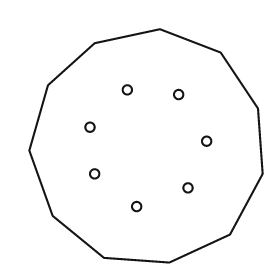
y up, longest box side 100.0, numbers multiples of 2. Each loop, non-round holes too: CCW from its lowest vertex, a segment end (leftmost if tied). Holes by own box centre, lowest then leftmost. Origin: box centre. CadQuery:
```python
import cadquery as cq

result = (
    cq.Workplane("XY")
    .moveTo(10.0, -50.0)
    .lineTo(36.0, -38.0)
    .lineTo(50.0, -12.0)
    .lineTo(48.0, 16.0)
    .lineTo(32.0, 40.0)
    .lineTo(6.0, 50.0)
    .lineTo(-22.0, 44.0)
    .lineTo(-42.0, 26.0)
    .lineTo(-50.0, -2.0)
    .lineTo(-40.0, -30.0)
    .lineTo(-18.0, -48.0)
    .close()
    .moveTo(-4.0, -26.0)
    .circle(2.0)
    .moveTo(18.0, -18.0)
    .circle(2.0)
    .moveTo(-22.0, -12.0)
    .circle(2.0)
    .moveTo(26.0, 2.0)
    .circle(2.0)
    .moveTo(-24.0, 8.0)
    .circle(2.0)
    .moveTo(14.0, 22.0)
    .circle(2.0)
    .moveTo(-8.0, 24.0)
    .circle(2.0)
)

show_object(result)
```